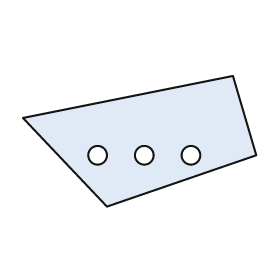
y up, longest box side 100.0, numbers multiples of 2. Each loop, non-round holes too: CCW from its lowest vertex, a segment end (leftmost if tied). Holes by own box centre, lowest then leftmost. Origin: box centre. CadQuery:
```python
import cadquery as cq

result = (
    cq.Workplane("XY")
    .moveTo(-14.0, -28.0)
    .lineTo(50.0, -6.0)
    .lineTo(40.0, 28.0)
    .lineTo(-50.0, 10.0)
    .close()
    .moveTo(-18.0, -6.0)
    .circle(4.0)
    .moveTo(2.0, -6.0)
    .circle(4.0)
    .moveTo(22.0, -6.0)
    .circle(4.0)
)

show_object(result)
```